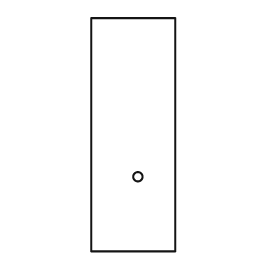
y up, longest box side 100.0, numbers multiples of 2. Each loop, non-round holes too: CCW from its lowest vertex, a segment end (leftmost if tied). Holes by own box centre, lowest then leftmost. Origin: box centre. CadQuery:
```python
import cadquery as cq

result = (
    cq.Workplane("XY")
    .moveTo(-18.0, -50.0)
    .lineTo(18.0, -50.0)
    .lineTo(18.0, 50.0)
    .lineTo(-18.0, 50.0)
    .close()
    .moveTo(2.0, -18.0)
    .circle(2.0)
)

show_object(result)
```